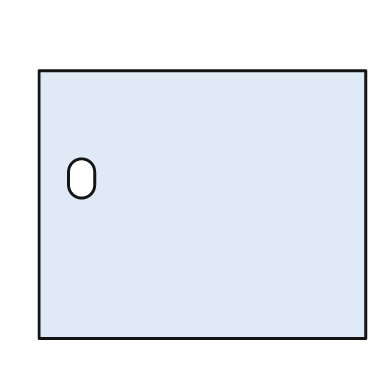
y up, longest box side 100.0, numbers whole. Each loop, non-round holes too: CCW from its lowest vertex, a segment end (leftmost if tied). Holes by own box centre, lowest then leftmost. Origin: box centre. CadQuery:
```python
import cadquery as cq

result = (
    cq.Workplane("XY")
    .moveTo(-50.0, -41.0)
    .lineTo(50.0, -41.0)
    .lineTo(50.0, 41.0)
    .lineTo(-50.0, 41.0)
    .close()
    .moveTo(-41.0, 6.0)
    .threePointArc((-37.0, 2.0), (-33.0, 6.0))
    .lineTo(-33.0, 10.0)
    .threePointArc((-37.0, 14.0), (-41.0, 10.0))
    .close()
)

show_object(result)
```